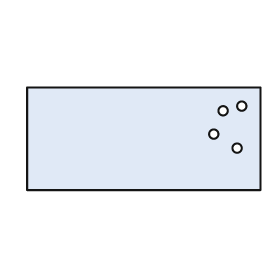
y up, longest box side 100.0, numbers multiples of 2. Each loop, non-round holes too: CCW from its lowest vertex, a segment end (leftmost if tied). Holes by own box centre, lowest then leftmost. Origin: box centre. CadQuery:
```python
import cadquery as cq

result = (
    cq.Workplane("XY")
    .moveTo(-50.0, -22.0)
    .lineTo(50.0, -22.0)
    .lineTo(50.0, 22.0)
    .lineTo(-50.0, 22.0)
    .close()
    .moveTo(40.0, -4.0)
    .circle(2.0)
    .moveTo(30.0, 2.0)
    .circle(2.0)
    .moveTo(34.0, 12.0)
    .circle(2.0)
    .moveTo(42.0, 14.0)
    .circle(2.0)
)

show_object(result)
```